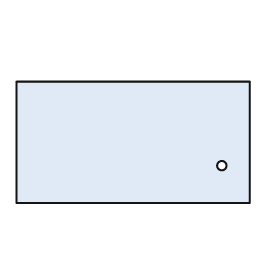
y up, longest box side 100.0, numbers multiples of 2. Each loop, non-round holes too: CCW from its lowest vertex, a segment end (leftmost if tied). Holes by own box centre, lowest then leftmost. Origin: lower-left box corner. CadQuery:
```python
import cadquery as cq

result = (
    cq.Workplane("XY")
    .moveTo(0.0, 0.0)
    .lineTo(100.0, 0.0)
    .lineTo(100.0, 52.0)
    .lineTo(0.0, 52.0)
    .close()
    .moveTo(88.0, 16.0)
    .circle(2.0)
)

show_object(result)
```